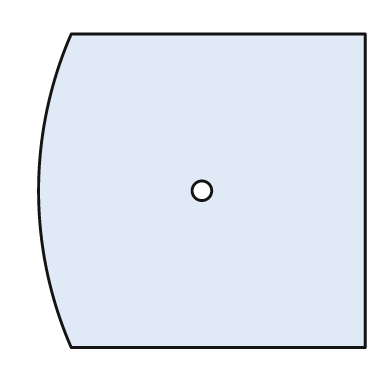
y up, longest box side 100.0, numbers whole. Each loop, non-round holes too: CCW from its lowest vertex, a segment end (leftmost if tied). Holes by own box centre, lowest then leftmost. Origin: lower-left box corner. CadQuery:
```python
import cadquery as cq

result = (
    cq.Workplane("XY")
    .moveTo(10.0, 0.0)
    .lineTo(100.0, 0.0)
    .lineTo(100.0, 96.0)
    .lineTo(10.0, 96.0)
    .threePointArc((0.0, 48.0), (10.0, 0.0))
    .close()
    .moveTo(50.0, 48.0)
    .circle(3.0)
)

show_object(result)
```